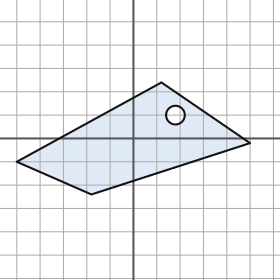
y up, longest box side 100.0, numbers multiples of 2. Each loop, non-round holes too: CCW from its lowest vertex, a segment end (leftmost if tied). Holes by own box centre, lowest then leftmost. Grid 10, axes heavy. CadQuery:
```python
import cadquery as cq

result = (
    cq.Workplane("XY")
    .moveTo(-18.0, -24.0)
    .lineTo(50.0, -2.0)
    .lineTo(12.0, 24.0)
    .lineTo(-50.0, -10.0)
    .close()
    .moveTo(18.0, 10.0)
    .circle(4.0)
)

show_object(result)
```